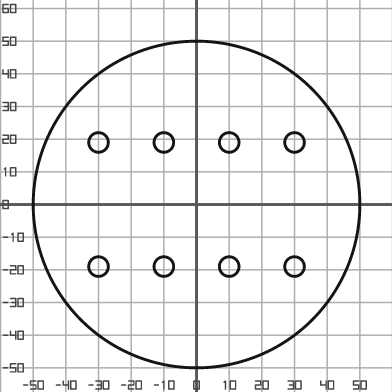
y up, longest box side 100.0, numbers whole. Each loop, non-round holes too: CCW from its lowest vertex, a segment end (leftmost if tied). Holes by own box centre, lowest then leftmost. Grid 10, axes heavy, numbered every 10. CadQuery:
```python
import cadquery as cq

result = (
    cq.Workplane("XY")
    .moveTo(0.0, 0.0)
    .circle(50.0)
    .moveTo(-30.0, -19.0)
    .circle(3.0)
    .moveTo(-10.0, -19.0)
    .circle(3.0)
    .moveTo(10.0, -19.0)
    .circle(3.0)
    .moveTo(30.0, -19.0)
    .circle(3.0)
    .moveTo(-30.0, 19.0)
    .circle(3.0)
    .moveTo(-10.0, 19.0)
    .circle(3.0)
    .moveTo(10.0, 19.0)
    .circle(3.0)
    .moveTo(30.0, 19.0)
    .circle(3.0)
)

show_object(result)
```